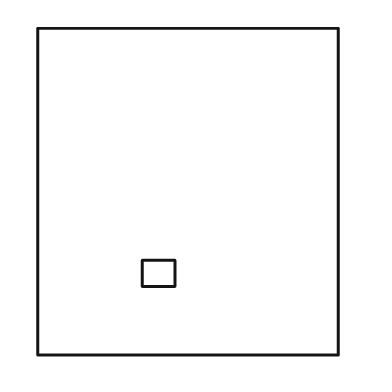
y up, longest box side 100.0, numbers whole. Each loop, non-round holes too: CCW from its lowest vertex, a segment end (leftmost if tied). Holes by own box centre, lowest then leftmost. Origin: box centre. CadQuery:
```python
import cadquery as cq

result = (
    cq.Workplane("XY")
    .moveTo(-46.0, -50.0)
    .lineTo(46.0, -50.0)
    .lineTo(46.0, 50.0)
    .lineTo(-46.0, 50.0)
    .close()
    .moveTo(-14.0, -29.0)
    .lineTo(-4.0, -29.0)
    .lineTo(-4.0, -21.0)
    .lineTo(-14.0, -21.0)
    .close()
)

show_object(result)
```